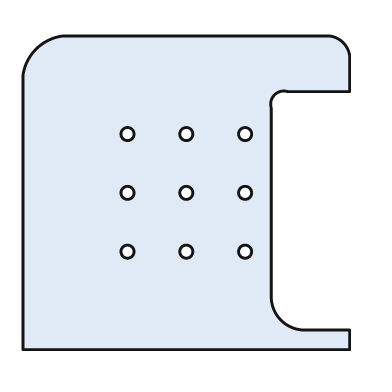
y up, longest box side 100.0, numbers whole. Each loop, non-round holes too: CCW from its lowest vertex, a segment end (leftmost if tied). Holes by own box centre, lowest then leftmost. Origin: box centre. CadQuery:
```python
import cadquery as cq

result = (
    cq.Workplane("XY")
    .moveTo(-50.0, -48.0)
    .lineTo(50.0, -48.0)
    .lineTo(50.0, -42.0)
    .lineTo(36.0, -42.0)
    .threePointArc((29.0, -39.0), (26.0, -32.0))
    .lineTo(26.0, 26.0)
    .threePointArc((27.0, 30.0), (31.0, 31.0))
    .lineTo(50.0, 31.0)
    .lineTo(50.0, 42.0)
    .threePointArc((48.0, 46.0), (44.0, 48.0))
    .lineTo(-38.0, 48.0)
    .threePointArc((-46.0, 44.0), (-50.0, 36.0))
    .close()
    .moveTo(-18.0, -18.0)
    .circle(2.0)
    .moveTo(0.0, -18.0)
    .circle(2.0)
    .moveTo(18.0, -18.0)
    .circle(2.0)
    .moveTo(-18.0, 0.0)
    .circle(2.0)
    .moveTo(0.0, 0.0)
    .circle(2.0)
    .moveTo(18.0, 0.0)
    .circle(2.0)
    .moveTo(-18.0, 18.0)
    .circle(2.0)
    .moveTo(0.0, 18.0)
    .circle(2.0)
    .moveTo(18.0, 18.0)
    .circle(2.0)
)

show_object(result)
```